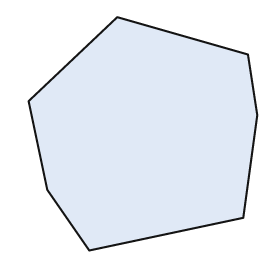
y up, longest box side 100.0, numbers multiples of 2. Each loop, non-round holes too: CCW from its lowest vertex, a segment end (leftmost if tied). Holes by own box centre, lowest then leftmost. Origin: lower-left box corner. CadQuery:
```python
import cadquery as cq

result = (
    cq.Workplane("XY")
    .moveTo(26.0, 0.0)
    .lineTo(92.0, 14.0)
    .lineTo(98.0, 58.0)
    .lineTo(94.0, 84.0)
    .lineTo(38.0, 100.0)
    .lineTo(0.0, 64.0)
    .lineTo(8.0, 26.0)
    .close()
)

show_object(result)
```